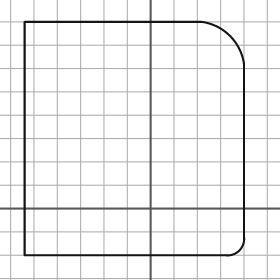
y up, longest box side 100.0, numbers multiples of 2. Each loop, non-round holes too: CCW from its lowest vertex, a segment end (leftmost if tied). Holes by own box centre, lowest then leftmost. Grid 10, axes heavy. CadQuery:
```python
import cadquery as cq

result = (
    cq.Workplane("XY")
    .moveTo(-54.0, -20.0)
    .lineTo(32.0, -20.0)
    .threePointArc((38.0, -18.0), (40.0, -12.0))
    .lineTo(40.0, 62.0)
    .threePointArc((34.0, 74.0), (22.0, 80.0))
    .lineTo(-54.0, 80.0)
    .close()
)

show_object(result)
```